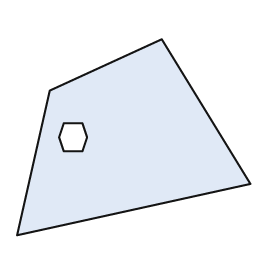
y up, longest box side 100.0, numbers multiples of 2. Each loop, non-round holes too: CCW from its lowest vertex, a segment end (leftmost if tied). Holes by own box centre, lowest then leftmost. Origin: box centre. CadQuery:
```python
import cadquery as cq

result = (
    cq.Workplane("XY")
    .moveTo(-50.0, -42.0)
    .lineTo(50.0, -20.0)
    .lineTo(12.0, 42.0)
    .lineTo(-36.0, 20.0)
    .close()
    .moveTo(-30.0, -6.0)
    .lineTo(-22.0, -6.0)
    .lineTo(-20.0, 0.0)
    .lineTo(-22.0, 6.0)
    .lineTo(-30.0, 6.0)
    .lineTo(-32.0, 0.0)
    .close()
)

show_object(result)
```